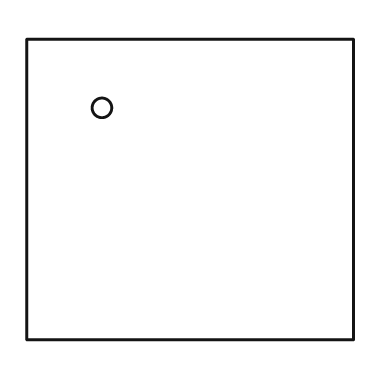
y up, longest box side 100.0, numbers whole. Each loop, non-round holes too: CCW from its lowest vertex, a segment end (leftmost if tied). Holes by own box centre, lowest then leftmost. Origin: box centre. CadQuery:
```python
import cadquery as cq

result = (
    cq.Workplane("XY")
    .moveTo(-50.0, -46.0)
    .lineTo(50.0, -46.0)
    .lineTo(50.0, 46.0)
    .lineTo(-50.0, 46.0)
    .close()
    .moveTo(-27.0, 25.0)
    .circle(3.0)
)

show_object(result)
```